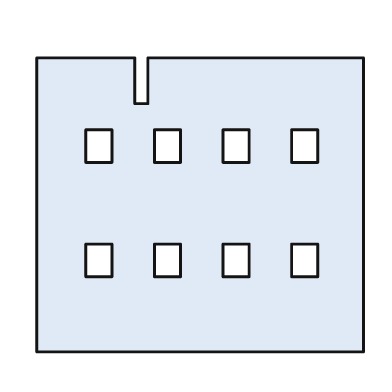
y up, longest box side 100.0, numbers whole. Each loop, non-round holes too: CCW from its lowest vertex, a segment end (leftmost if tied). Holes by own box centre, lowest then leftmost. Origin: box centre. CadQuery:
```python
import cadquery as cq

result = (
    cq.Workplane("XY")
    .moveTo(-50.0, -45.0)
    .lineTo(50.0, -45.0)
    .lineTo(50.0, 45.0)
    .lineTo(-16.0, 45.0)
    .lineTo(-16.0, 31.0)
    .lineTo(-20.0, 31.0)
    .lineTo(-20.0, 45.0)
    .lineTo(-50.0, 45.0)
    .close()
    .moveTo(-35.0, -22.0)
    .lineTo(-27.0, -22.0)
    .lineTo(-27.0, -12.0)
    .lineTo(-35.0, -12.0)
    .close()
    .moveTo(-14.0, -22.0)
    .lineTo(-6.0, -22.0)
    .lineTo(-6.0, -12.0)
    .lineTo(-14.0, -12.0)
    .close()
    .moveTo(7.0, -22.0)
    .lineTo(15.0, -22.0)
    .lineTo(15.0, -12.0)
    .lineTo(7.0, -12.0)
    .close()
    .moveTo(28.0, -22.0)
    .lineTo(36.0, -22.0)
    .lineTo(36.0, -12.0)
    .lineTo(28.0, -12.0)
    .close()
    .moveTo(-35.0, 13.0)
    .lineTo(-27.0, 13.0)
    .lineTo(-27.0, 23.0)
    .lineTo(-35.0, 23.0)
    .close()
    .moveTo(-14.0, 13.0)
    .lineTo(-6.0, 13.0)
    .lineTo(-6.0, 23.0)
    .lineTo(-14.0, 23.0)
    .close()
    .moveTo(7.0, 13.0)
    .lineTo(15.0, 13.0)
    .lineTo(15.0, 23.0)
    .lineTo(7.0, 23.0)
    .close()
    .moveTo(28.0, 13.0)
    .lineTo(36.0, 13.0)
    .lineTo(36.0, 23.0)
    .lineTo(28.0, 23.0)
    .close()
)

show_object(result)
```